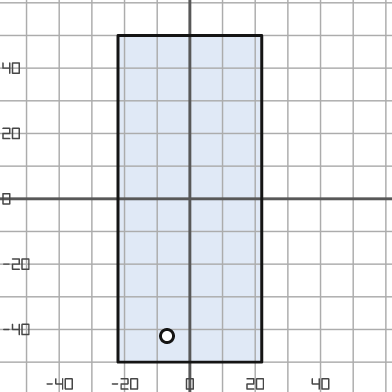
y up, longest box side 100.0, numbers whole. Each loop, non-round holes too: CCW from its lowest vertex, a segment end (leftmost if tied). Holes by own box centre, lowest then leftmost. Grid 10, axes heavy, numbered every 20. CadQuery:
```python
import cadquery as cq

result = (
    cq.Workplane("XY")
    .moveTo(-22.0, -50.0)
    .lineTo(22.0, -50.0)
    .lineTo(22.0, 50.0)
    .lineTo(-22.0, 50.0)
    .close()
    .moveTo(-7.0, -42.0)
    .circle(2.0)
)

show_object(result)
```